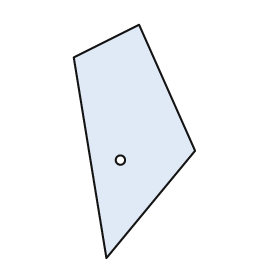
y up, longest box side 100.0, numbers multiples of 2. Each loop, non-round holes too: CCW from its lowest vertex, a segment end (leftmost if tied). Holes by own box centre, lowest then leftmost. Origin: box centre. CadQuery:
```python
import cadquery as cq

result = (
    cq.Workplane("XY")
    .moveTo(-12.0, -50.0)
    .lineTo(26.0, -4.0)
    .lineTo(2.0, 50.0)
    .lineTo(-26.0, 36.0)
    .close()
    .moveTo(-6.0, -8.0)
    .circle(2.0)
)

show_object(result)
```